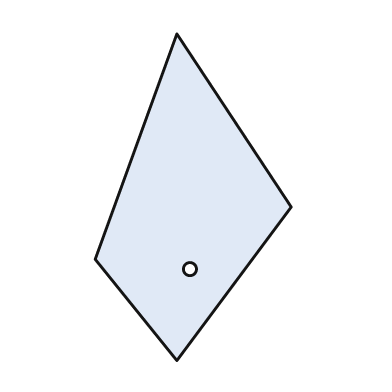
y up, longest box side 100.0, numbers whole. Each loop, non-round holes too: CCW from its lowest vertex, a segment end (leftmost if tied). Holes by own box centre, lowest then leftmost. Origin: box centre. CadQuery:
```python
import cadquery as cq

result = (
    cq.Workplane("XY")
    .moveTo(-5.0, -50.0)
    .lineTo(30.0, -3.0)
    .lineTo(-5.0, 50.0)
    .lineTo(-30.0, -19.0)
    .close()
    .moveTo(-1.0, -22.0)
    .circle(2.0)
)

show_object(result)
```